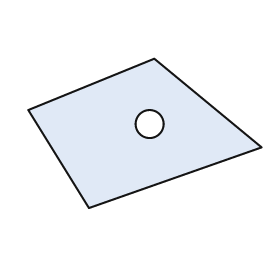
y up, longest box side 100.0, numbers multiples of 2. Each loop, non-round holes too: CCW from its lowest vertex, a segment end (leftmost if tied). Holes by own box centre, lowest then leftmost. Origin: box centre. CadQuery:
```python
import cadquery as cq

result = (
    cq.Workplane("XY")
    .moveTo(-24.0, -32.0)
    .lineTo(50.0, -6.0)
    .lineTo(4.0, 32.0)
    .lineTo(-50.0, 10.0)
    .close()
    .moveTo(2.0, 4.0)
    .circle(6.0)
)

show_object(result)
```